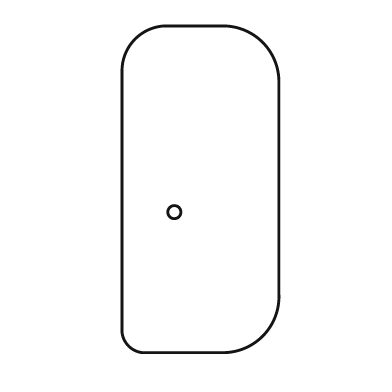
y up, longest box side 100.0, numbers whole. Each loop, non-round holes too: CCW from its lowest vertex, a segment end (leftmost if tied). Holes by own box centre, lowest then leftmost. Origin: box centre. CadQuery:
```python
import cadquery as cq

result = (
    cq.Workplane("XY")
    .moveTo(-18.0, -50.0)
    .lineTo(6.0, -50.0)
    .threePointArc((19.0, -45.0), (24.0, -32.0))
    .lineTo(24.0, 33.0)
    .threePointArc((19.0, 45.0), (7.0, 50.0))
    .lineTo(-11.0, 50.0)
    .threePointArc((-20.0, 46.0), (-24.0, 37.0))
    .lineTo(-24.0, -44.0)
    .threePointArc((-22.0, -48.0), (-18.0, -50.0))
    .close()
    .moveTo(-8.0, -7.0)
    .circle(2.0)
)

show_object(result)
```